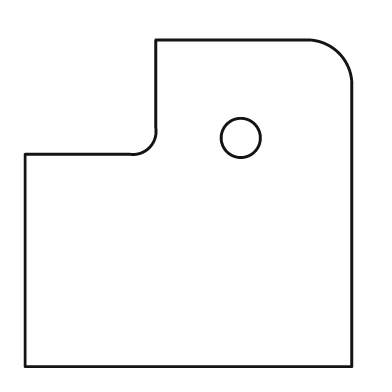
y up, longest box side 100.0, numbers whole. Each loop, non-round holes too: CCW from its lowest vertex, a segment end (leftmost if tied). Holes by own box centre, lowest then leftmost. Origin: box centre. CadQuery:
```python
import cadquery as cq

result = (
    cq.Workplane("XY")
    .moveTo(-50.0, -50.0)
    .lineTo(50.0, -50.0)
    .lineTo(50.0, 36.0)
    .threePointArc((46.0, 46.0), (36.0, 50.0))
    .lineTo(-10.0, 50.0)
    .lineTo(-10.0, 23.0)
    .threePointArc((-12.0, 17.0), (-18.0, 15.0))
    .lineTo(-50.0, 15.0)
    .close()
    .moveTo(16.0, 20.0)
    .circle(6.0)
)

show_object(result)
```